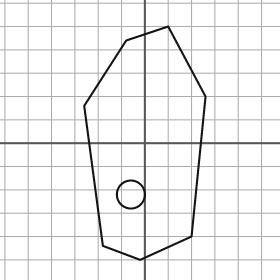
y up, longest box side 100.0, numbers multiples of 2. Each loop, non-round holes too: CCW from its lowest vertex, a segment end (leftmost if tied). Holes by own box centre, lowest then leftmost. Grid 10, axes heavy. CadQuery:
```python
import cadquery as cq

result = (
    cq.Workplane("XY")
    .moveTo(-2.0, -50.0)
    .lineTo(20.0, -40.0)
    .lineTo(26.0, 20.0)
    .lineTo(10.0, 50.0)
    .lineTo(-8.0, 44.0)
    .lineTo(-26.0, 16.0)
    .lineTo(-18.0, -44.0)
    .close()
    .moveTo(-6.0, -22.0)
    .circle(6.0)
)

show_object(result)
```